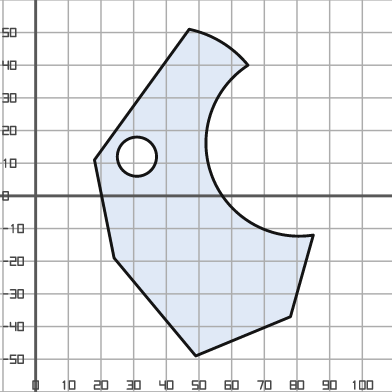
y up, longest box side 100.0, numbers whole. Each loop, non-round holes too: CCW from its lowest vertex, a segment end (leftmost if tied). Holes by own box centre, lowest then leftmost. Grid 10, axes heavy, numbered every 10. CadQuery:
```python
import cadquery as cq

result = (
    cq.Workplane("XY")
    .moveTo(49.0, -49.0)
    .lineTo(78.0, -37.0)
    .lineTo(85.0, -12.0)
    .threePointArc((54.0, 6.0), (65.0, 40.0))
    .threePointArc((57.0, 47.0), (47.0, 51.0))
    .lineTo(18.0, 11.0)
    .lineTo(24.0, -19.0)
    .close()
    .moveTo(31.0, 12.0)
    .circle(6.0)
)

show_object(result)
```